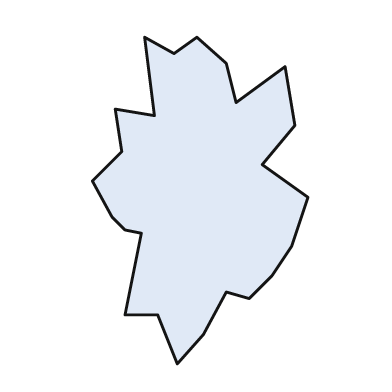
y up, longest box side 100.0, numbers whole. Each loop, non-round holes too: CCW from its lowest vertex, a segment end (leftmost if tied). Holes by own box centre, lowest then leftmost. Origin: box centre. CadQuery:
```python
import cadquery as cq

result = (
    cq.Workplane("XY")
    .moveTo(-7.0, -50.0)
    .lineTo(1.0, -41.0)
    .lineTo(8.0, -28.0)
    .lineTo(15.0, -30.0)
    .lineTo(22.0, -23.0)
    .lineTo(28.0, -14.0)
    .lineTo(33.0, 1.0)
    .lineTo(19.0, 11.0)
    .lineTo(29.0, 23.0)
    .lineTo(26.0, 41.0)
    .lineTo(11.0, 30.0)
    .lineTo(8.0, 42.0)
    .lineTo(-1.0, 50.0)
    .lineTo(-8.0, 45.0)
    .lineTo(-17.0, 50.0)
    .lineTo(-14.0, 26.0)
    .lineTo(-26.0, 28.0)
    .lineTo(-24.0, 15.0)
    .lineTo(-33.0, 6.0)
    .lineTo(-27.0, -5.0)
    .lineTo(-23.0, -9.0)
    .lineTo(-18.0, -10.0)
    .lineTo(-23.0, -35.0)
    .lineTo(-13.0, -35.0)
    .close()
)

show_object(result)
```